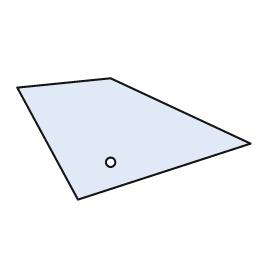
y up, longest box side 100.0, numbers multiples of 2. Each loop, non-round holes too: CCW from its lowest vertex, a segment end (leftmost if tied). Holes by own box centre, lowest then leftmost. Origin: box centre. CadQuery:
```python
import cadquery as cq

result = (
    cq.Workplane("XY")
    .moveTo(-24.0, -26.0)
    .lineTo(50.0, -2.0)
    .lineTo(-10.0, 26.0)
    .lineTo(-50.0, 22.0)
    .close()
    .moveTo(-10.0, -10.0)
    .circle(2.0)
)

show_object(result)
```